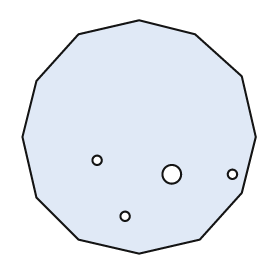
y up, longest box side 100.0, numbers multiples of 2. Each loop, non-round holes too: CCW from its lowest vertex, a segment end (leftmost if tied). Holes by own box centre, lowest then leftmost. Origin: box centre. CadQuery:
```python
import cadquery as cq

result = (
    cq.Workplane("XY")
    .moveTo(0.0, -50.0)
    .lineTo(26.0, -44.0)
    .lineTo(44.0, -24.0)
    .lineTo(50.0, 0.0)
    .lineTo(44.0, 26.0)
    .lineTo(24.0, 44.0)
    .lineTo(0.0, 50.0)
    .lineTo(-26.0, 44.0)
    .lineTo(-44.0, 24.0)
    .lineTo(-50.0, 0.0)
    .lineTo(-44.0, -26.0)
    .lineTo(-26.0, -44.0)
    .close()
    .moveTo(-6.0, -34.0)
    .circle(2.0)
    .moveTo(14.0, -16.0)
    .circle(4.0)
    .moveTo(40.0, -16.0)
    .circle(2.0)
    .moveTo(-18.0, -10.0)
    .circle(2.0)
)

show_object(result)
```